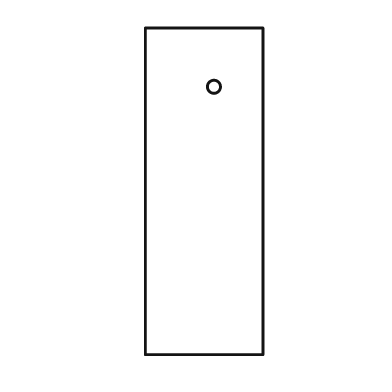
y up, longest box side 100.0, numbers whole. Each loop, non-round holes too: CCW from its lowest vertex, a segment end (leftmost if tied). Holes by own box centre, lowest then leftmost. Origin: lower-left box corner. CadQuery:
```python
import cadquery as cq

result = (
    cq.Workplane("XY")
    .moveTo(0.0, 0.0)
    .lineTo(36.0, 0.0)
    .lineTo(36.0, 100.0)
    .lineTo(0.0, 100.0)
    .close()
    .moveTo(21.0, 82.0)
    .circle(2.0)
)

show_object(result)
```